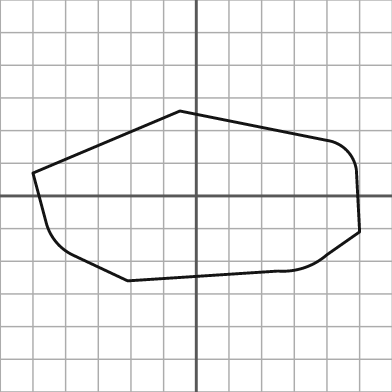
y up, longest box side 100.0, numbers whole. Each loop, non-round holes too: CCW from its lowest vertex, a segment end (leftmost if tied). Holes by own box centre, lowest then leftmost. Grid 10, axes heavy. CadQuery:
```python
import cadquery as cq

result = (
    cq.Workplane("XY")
    .moveTo(-21.0, -26.0)
    .lineTo(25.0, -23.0)
    .threePointArc((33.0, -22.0), (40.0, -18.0))
    .lineTo(50.0, -11.0)
    .lineTo(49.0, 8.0)
    .threePointArc((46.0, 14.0), (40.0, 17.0))
    .lineTo(-5.0, 26.0)
    .lineTo(-50.0, 7.0)
    .lineTo(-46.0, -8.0)
    .threePointArc((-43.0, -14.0), (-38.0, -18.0))
    .close()
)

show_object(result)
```